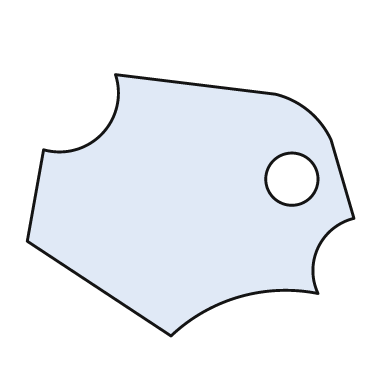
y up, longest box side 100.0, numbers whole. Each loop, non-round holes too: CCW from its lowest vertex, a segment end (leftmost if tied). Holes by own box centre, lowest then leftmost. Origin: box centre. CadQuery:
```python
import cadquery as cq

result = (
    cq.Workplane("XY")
    .moveTo(-6.0, -40.0)
    .threePointArc((15.0, -28.0), (39.0, -27.0))
    .threePointArc((39.0, -13.0), (50.0, -4.0))
    .lineTo(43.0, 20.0)
    .threePointArc((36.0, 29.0), (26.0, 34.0))
    .lineTo(-23.0, 40.0)
    .threePointArc((-27.0, 22.0), (-45.0, 17.0))
    .lineTo(-50.0, -11.0)
    .close()
    .moveTo(31.0, 8.0)
    .circle(8.0)
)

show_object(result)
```